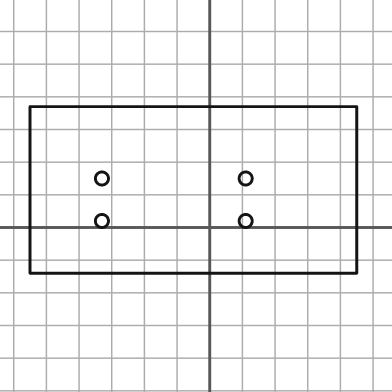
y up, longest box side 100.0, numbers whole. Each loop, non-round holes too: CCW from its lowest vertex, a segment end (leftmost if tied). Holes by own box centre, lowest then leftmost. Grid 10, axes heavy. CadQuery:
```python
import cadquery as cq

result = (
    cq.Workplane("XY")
    .moveTo(-55.0, -14.0)
    .lineTo(45.0, -14.0)
    .lineTo(45.0, 37.0)
    .lineTo(-55.0, 37.0)
    .close()
    .moveTo(-33.0, 2.0)
    .circle(2.0)
    .moveTo(11.0, 2.0)
    .circle(2.0)
    .moveTo(-33.0, 15.0)
    .circle(2.0)
    .moveTo(11.0, 15.0)
    .circle(2.0)
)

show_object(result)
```